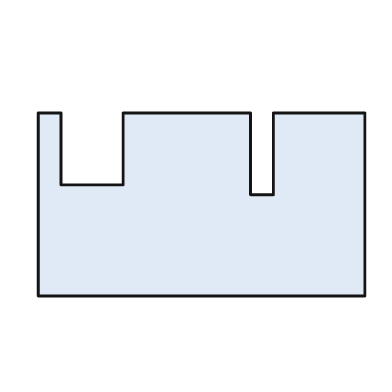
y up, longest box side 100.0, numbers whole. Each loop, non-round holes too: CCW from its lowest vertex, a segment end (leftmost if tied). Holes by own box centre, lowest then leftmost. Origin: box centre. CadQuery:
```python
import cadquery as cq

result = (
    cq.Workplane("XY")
    .moveTo(-50.0, -28.0)
    .lineTo(50.0, -28.0)
    .lineTo(50.0, 28.0)
    .lineTo(22.0, 28.0)
    .lineTo(22.0, 3.0)
    .lineTo(15.0, 3.0)
    .lineTo(15.0, 28.0)
    .lineTo(-24.0, 28.0)
    .lineTo(-24.0, 6.0)
    .lineTo(-43.0, 6.0)
    .lineTo(-43.0, 28.0)
    .lineTo(-50.0, 28.0)
    .close()
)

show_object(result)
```